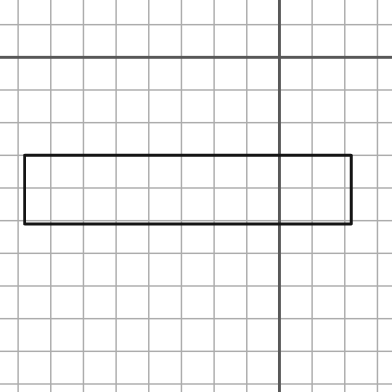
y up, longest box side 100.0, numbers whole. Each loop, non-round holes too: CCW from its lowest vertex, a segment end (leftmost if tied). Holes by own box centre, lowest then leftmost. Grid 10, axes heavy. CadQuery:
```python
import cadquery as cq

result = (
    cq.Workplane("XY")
    .moveTo(-78.0, -51.0)
    .lineTo(22.0, -51.0)
    .lineTo(22.0, -30.0)
    .lineTo(-78.0, -30.0)
    .close()
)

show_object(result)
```